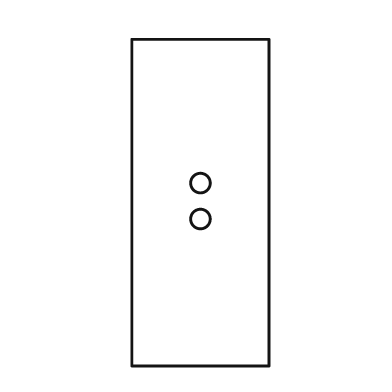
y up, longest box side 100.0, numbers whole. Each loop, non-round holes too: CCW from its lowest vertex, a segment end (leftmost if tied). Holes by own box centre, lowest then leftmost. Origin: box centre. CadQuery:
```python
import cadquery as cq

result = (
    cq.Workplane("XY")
    .moveTo(-21.0, -50.0)
    .lineTo(21.0, -50.0)
    .lineTo(21.0, 50.0)
    .lineTo(-21.0, 50.0)
    .close()
    .moveTo(0.0, -5.0)
    .circle(3.0)
    .moveTo(0.0, 6.0)
    .circle(3.0)
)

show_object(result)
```